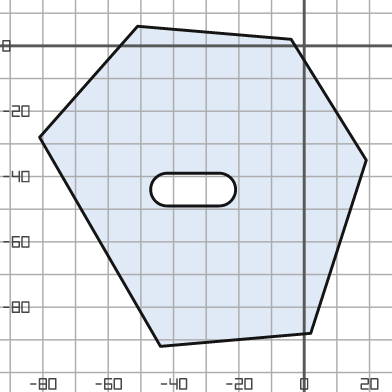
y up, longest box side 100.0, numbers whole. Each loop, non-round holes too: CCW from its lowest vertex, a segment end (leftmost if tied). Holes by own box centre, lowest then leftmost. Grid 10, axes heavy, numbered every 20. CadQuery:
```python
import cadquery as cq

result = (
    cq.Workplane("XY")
    .moveTo(-44.0, -92.0)
    .lineTo(2.0, -88.0)
    .lineTo(19.0, -35.0)
    .lineTo(-4.0, 2.0)
    .lineTo(-51.0, 6.0)
    .lineTo(-81.0, -28.0)
    .close()
    .moveTo(-42.0, -49.0)
    .lineTo(-26.0, -49.0)
    .threePointArc((-21.0, -44.0), (-26.0, -39.0))
    .lineTo(-42.0, -39.0)
    .threePointArc((-47.0, -44.0), (-42.0, -49.0))
    .close()
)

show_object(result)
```